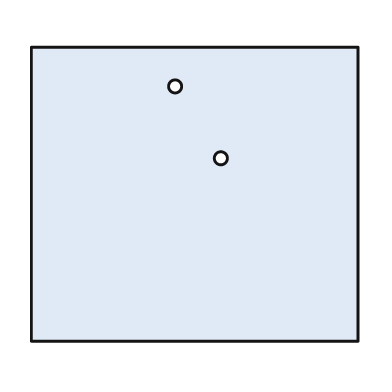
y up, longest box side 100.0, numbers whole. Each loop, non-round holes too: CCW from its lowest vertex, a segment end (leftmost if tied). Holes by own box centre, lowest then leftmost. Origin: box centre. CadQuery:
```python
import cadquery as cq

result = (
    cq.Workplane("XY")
    .moveTo(-50.0, -45.0)
    .lineTo(50.0, -45.0)
    .lineTo(50.0, 45.0)
    .lineTo(-50.0, 45.0)
    .close()
    .moveTo(8.0, 11.0)
    .circle(2.0)
    .moveTo(-6.0, 33.0)
    .circle(2.0)
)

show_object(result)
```